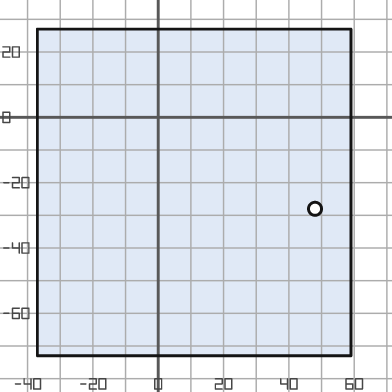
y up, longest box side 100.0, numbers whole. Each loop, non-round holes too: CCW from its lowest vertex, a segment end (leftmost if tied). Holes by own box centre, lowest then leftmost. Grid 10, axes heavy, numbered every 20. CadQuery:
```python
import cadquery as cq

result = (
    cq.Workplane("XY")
    .moveTo(-37.0, -73.0)
    .lineTo(59.0, -73.0)
    .lineTo(59.0, 27.0)
    .lineTo(-37.0, 27.0)
    .close()
    .moveTo(48.0, -28.0)
    .circle(2.0)
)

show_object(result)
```